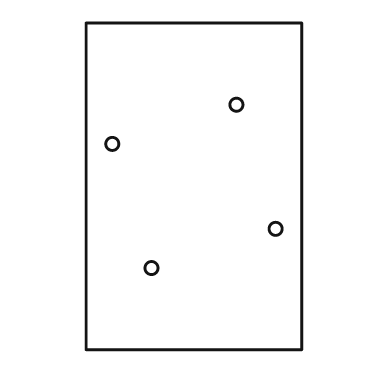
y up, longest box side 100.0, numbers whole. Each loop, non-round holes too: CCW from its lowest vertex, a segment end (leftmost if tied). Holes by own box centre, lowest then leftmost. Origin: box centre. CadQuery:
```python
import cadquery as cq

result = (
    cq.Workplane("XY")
    .moveTo(-33.0, -50.0)
    .lineTo(33.0, -50.0)
    .lineTo(33.0, 50.0)
    .lineTo(-33.0, 50.0)
    .close()
    .moveTo(-13.0, -25.0)
    .circle(2.0)
    .moveTo(25.0, -13.0)
    .circle(2.0)
    .moveTo(-25.0, 13.0)
    .circle(2.0)
    .moveTo(13.0, 25.0)
    .circle(2.0)
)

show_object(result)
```